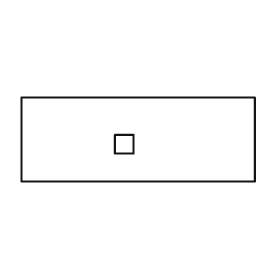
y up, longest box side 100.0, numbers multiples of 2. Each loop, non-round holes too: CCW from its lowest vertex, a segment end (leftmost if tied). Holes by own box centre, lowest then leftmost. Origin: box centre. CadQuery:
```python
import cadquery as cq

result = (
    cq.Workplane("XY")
    .moveTo(-50.0, -18.0)
    .lineTo(50.0, -18.0)
    .lineTo(50.0, 18.0)
    .lineTo(-50.0, 18.0)
    .close()
    .moveTo(-10.0, -6.0)
    .lineTo(-2.0, -6.0)
    .lineTo(-2.0, 2.0)
    .lineTo(-10.0, 2.0)
    .close()
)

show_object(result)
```